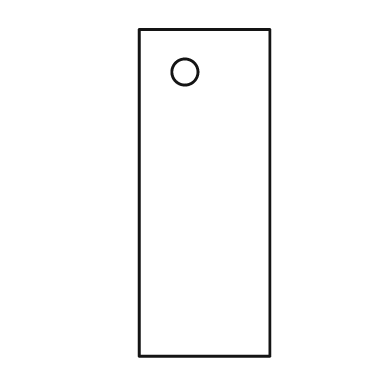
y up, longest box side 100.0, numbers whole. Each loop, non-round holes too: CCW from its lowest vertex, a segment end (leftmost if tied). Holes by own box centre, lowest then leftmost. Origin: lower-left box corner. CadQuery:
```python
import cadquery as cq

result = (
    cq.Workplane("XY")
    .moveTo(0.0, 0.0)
    .lineTo(40.0, 0.0)
    .lineTo(40.0, 100.0)
    .lineTo(0.0, 100.0)
    .close()
    .moveTo(14.0, 87.0)
    .circle(4.0)
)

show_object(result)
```